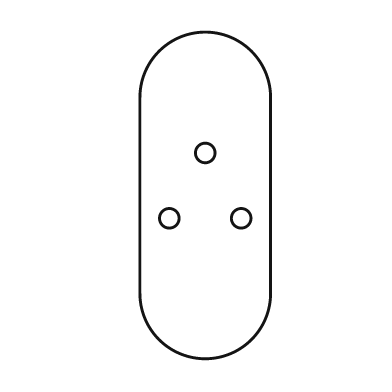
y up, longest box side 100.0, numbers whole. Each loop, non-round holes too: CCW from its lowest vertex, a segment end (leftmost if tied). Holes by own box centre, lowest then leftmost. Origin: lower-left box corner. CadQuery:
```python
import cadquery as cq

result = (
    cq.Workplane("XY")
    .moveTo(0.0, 20.0)
    .threePointArc((20.0, 0.0), (40.0, 20.0))
    .lineTo(40.0, 80.0)
    .threePointArc((20.0, 100.0), (0.0, 80.0))
    .close()
    .moveTo(9.0, 43.0)
    .circle(3.0)
    .moveTo(31.0, 43.0)
    .circle(3.0)
    .moveTo(20.0, 63.0)
    .circle(3.0)
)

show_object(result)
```